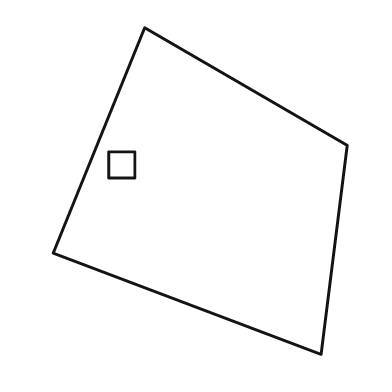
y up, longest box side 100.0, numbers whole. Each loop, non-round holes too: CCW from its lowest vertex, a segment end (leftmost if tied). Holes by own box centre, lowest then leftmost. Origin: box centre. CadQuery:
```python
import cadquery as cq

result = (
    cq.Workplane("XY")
    .moveTo(37.0, -50.0)
    .lineTo(45.0, 14.0)
    .lineTo(-17.0, 50.0)
    .lineTo(-45.0, -19.0)
    .close()
    .moveTo(-28.0, 4.0)
    .lineTo(-20.0, 4.0)
    .lineTo(-20.0, 12.0)
    .lineTo(-28.0, 12.0)
    .close()
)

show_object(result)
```